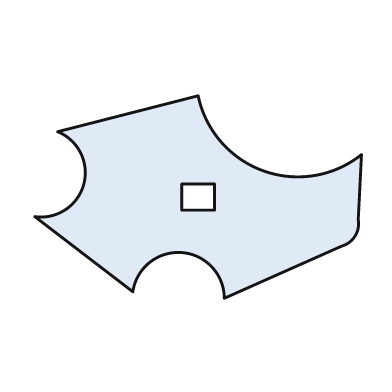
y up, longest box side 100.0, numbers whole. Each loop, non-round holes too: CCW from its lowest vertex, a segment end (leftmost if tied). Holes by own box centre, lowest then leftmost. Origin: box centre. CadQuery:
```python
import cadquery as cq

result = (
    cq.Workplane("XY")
    .moveTo(8.0, -31.0)
    .lineTo(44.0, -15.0)
    .threePointArc((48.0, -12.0), (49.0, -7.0))
    .lineTo(50.0, 13.0)
    .threePointArc((20.0, 8.0), (0.0, 31.0))
    .lineTo(-43.0, 20.0)
    .threePointArc((-35.0, 4.0), (-50.0, -6.0))
    .lineTo(-20.0, -29.0)
    .threePointArc((-5.0, -17.0), (8.0, -31.0))
    .close()
    .moveTo(-5.0, -4.0)
    .lineTo(5.0, -4.0)
    .lineTo(5.0, 4.0)
    .lineTo(-5.0, 4.0)
    .close()
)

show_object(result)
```